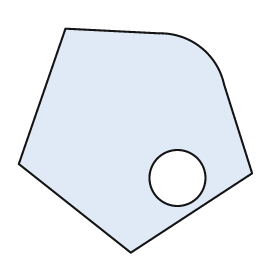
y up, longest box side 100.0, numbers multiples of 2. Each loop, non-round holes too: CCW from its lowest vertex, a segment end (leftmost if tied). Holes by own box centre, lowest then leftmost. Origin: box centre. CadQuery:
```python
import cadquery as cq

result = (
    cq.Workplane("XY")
    .moveTo(-2.0, -48.0)
    .lineTo(50.0, -14.0)
    .lineTo(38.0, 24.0)
    .threePointArc((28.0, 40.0), (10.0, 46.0))
    .lineTo(-30.0, 48.0)
    .lineTo(-50.0, -10.0)
    .close()
    .moveTo(18.0, -16.0)
    .circle(12.0)
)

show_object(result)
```